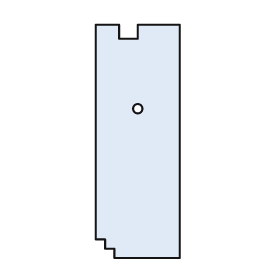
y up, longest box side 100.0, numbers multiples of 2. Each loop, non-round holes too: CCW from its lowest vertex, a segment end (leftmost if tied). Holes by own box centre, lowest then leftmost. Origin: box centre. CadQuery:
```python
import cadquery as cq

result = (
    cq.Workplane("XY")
    .moveTo(-10.0, -50.0)
    .lineTo(18.0, -50.0)
    .lineTo(18.0, 50.0)
    .lineTo(0.0, 50.0)
    .lineTo(0.0, 44.0)
    .lineTo(-8.0, 44.0)
    .lineTo(-8.0, 50.0)
    .lineTo(-18.0, 50.0)
    .lineTo(-18.0, -42.0)
    .lineTo(-14.0, -42.0)
    .lineTo(-14.0, -46.0)
    .lineTo(-10.0, -46.0)
    .close()
    .moveTo(0.0, 14.0)
    .circle(2.0)
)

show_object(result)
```